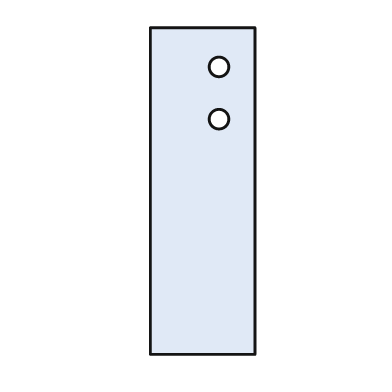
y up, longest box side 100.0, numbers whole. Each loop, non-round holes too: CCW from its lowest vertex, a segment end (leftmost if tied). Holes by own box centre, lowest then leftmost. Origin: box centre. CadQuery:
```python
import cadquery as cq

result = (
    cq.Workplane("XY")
    .moveTo(-16.0, -50.0)
    .lineTo(16.0, -50.0)
    .lineTo(16.0, 50.0)
    .lineTo(-16.0, 50.0)
    .close()
    .moveTo(5.0, 22.0)
    .circle(3.0)
    .moveTo(5.0, 38.0)
    .circle(3.0)
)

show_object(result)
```